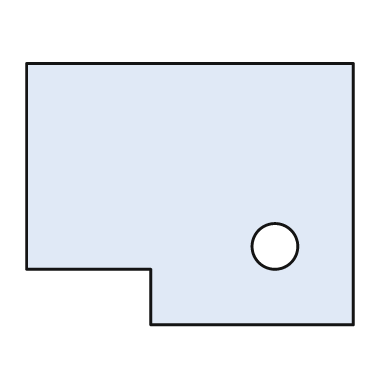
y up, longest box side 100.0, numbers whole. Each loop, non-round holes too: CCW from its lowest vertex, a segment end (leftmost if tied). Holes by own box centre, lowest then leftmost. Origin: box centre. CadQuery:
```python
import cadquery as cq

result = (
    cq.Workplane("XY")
    .moveTo(-12.0, -40.0)
    .lineTo(50.0, -40.0)
    .lineTo(50.0, 40.0)
    .lineTo(-50.0, 40.0)
    .lineTo(-50.0, -23.0)
    .lineTo(-12.0, -23.0)
    .close()
    .moveTo(26.0, -16.0)
    .circle(7.0)
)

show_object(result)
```